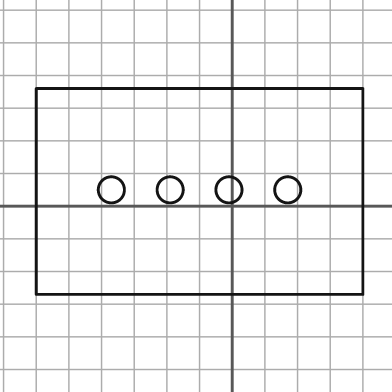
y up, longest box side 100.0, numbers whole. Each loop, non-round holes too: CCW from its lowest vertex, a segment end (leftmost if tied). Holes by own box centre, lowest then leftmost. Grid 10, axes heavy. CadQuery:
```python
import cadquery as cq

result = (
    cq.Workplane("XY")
    .moveTo(-60.0, -27.0)
    .lineTo(40.0, -27.0)
    .lineTo(40.0, 36.0)
    .lineTo(-60.0, 36.0)
    .close()
    .moveTo(-37.0, 5.0)
    .circle(4.0)
    .moveTo(-19.0, 5.0)
    .circle(4.0)
    .moveTo(-1.0, 5.0)
    .circle(4.0)
    .moveTo(17.0, 5.0)
    .circle(4.0)
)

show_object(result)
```